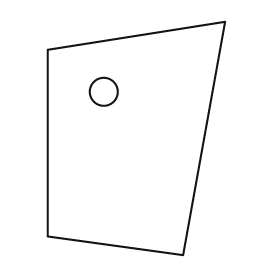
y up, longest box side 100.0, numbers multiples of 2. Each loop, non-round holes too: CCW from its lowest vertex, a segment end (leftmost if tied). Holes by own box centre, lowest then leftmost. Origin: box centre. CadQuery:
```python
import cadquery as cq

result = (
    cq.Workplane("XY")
    .moveTo(20.0, -50.0)
    .lineTo(38.0, 50.0)
    .lineTo(-38.0, 38.0)
    .lineTo(-38.0, -42.0)
    .close()
    .moveTo(-14.0, 20.0)
    .circle(6.0)
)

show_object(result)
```